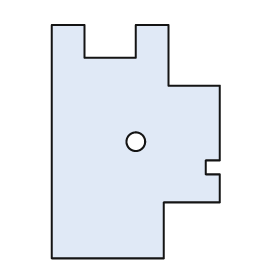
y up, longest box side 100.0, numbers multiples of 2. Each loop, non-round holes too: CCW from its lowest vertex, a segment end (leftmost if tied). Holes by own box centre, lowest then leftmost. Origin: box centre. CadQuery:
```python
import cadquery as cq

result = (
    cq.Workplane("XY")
    .moveTo(-36.0, -50.0)
    .lineTo(12.0, -50.0)
    .lineTo(12.0, -26.0)
    .lineTo(36.0, -26.0)
    .lineTo(36.0, -14.0)
    .lineTo(30.0, -14.0)
    .lineTo(30.0, -8.0)
    .lineTo(36.0, -8.0)
    .lineTo(36.0, 24.0)
    .lineTo(14.0, 24.0)
    .lineTo(14.0, 50.0)
    .lineTo(0.0, 50.0)
    .lineTo(0.0, 36.0)
    .lineTo(-22.0, 36.0)
    .lineTo(-22.0, 50.0)
    .lineTo(-36.0, 50.0)
    .close()
    .moveTo(0.0, 0.0)
    .circle(4.0)
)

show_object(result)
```